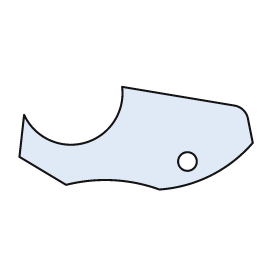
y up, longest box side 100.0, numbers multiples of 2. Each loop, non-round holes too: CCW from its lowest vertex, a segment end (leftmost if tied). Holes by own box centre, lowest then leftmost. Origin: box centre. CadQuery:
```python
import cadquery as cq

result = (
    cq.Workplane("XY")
    .moveTo(10.0, -22.0)
    .threePointArc((32.0, -16.0), (50.0, -2.0))
    .lineTo(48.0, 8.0)
    .threePointArc((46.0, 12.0), (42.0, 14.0))
    .lineTo(-6.0, 22.0)
    .threePointArc((-22.0, -2.0), (-48.0, 10.0))
    .lineTo(-50.0, -8.0)
    .lineTo(-30.0, -20.0)
    .threePointArc((-10.0, -18.0), (10.0, -22.0))
    .close()
    .moveTo(22.0, -10.0)
    .circle(4.0)
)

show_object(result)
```